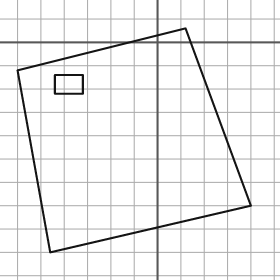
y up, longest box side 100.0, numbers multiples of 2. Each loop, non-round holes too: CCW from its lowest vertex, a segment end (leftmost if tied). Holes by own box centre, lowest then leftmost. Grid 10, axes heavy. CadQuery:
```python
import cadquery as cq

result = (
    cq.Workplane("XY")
    .moveTo(-46.0, -90.0)
    .lineTo(40.0, -70.0)
    .lineTo(12.0, 6.0)
    .lineTo(-60.0, -12.0)
    .close()
    .moveTo(-44.0, -22.0)
    .lineTo(-32.0, -22.0)
    .lineTo(-32.0, -14.0)
    .lineTo(-44.0, -14.0)
    .close()
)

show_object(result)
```